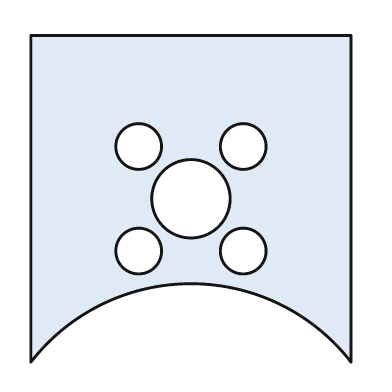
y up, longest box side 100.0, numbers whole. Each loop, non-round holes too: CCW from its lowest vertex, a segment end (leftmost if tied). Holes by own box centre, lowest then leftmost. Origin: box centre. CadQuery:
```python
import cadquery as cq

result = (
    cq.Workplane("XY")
    .moveTo(-49.0, -50.0)
    .threePointArc((0.0, -26.0), (49.0, -50.0))
    .lineTo(49.0, 50.0)
    .lineTo(-49.0, 50.0)
    .close()
    .moveTo(-16.0, -16.0)
    .circle(7.0)
    .moveTo(16.0, -16.0)
    .circle(7.0)
    .moveTo(0.0, 0.0)
    .circle(12.0)
    .moveTo(-16.0, 16.0)
    .circle(7.0)
    .moveTo(16.0, 16.0)
    .circle(7.0)
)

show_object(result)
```